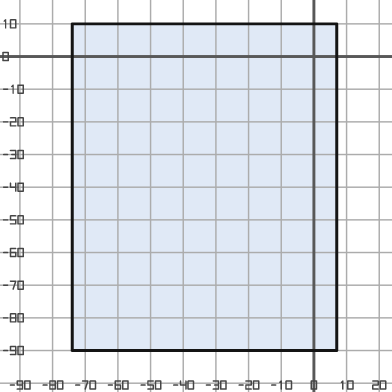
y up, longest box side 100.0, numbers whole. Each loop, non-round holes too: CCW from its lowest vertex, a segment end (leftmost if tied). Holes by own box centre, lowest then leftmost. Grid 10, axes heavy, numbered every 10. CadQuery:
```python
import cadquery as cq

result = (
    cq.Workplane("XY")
    .moveTo(-74.0, -90.0)
    .lineTo(7.0, -90.0)
    .lineTo(7.0, 10.0)
    .lineTo(-74.0, 10.0)
    .close()
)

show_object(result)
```